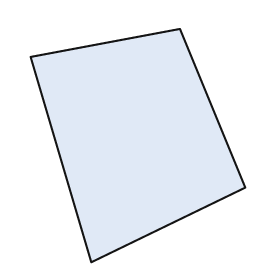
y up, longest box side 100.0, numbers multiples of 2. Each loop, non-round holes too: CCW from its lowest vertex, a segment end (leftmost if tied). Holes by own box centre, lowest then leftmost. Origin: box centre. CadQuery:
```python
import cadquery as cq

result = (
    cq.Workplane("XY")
    .moveTo(-20.0, -50.0)
    .lineTo(46.0, -18.0)
    .lineTo(18.0, 50.0)
    .lineTo(-46.0, 38.0)
    .close()
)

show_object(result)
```